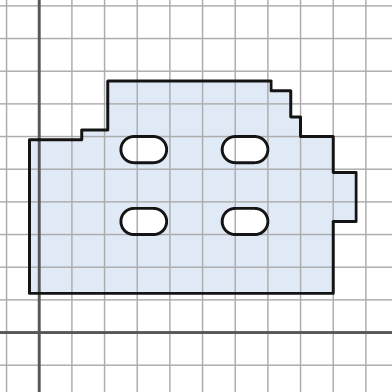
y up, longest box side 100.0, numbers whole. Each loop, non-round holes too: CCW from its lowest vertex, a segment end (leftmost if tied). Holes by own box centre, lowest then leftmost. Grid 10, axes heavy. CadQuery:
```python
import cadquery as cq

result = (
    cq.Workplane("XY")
    .moveTo(-3.0, 12.0)
    .lineTo(90.0, 12.0)
    .lineTo(90.0, 34.0)
    .lineTo(97.0, 34.0)
    .lineTo(97.0, 49.0)
    .lineTo(90.0, 49.0)
    .lineTo(90.0, 60.0)
    .lineTo(80.0, 60.0)
    .lineTo(80.0, 66.0)
    .lineTo(77.0, 66.0)
    .lineTo(77.0, 74.0)
    .lineTo(71.0, 74.0)
    .lineTo(71.0, 77.0)
    .lineTo(21.0, 77.0)
    .lineTo(21.0, 62.0)
    .lineTo(13.0, 62.0)
    .lineTo(13.0, 59.0)
    .lineTo(-3.0, 59.0)
    .close()
    .moveTo(29.0, 30.0)
    .lineTo(35.0, 30.0)
    .threePointArc((39.0, 34.0), (35.0, 38.0))
    .lineTo(29.0, 38.0)
    .threePointArc((25.0, 34.0), (29.0, 30.0))
    .close()
    .moveTo(60.0, 30.0)
    .lineTo(66.0, 30.0)
    .threePointArc((70.0, 34.0), (66.0, 38.0))
    .lineTo(60.0, 38.0)
    .threePointArc((56.0, 34.0), (60.0, 30.0))
    .close()
    .moveTo(29.0, 52.0)
    .lineTo(35.0, 52.0)
    .threePointArc((39.0, 56.0), (35.0, 60.0))
    .lineTo(29.0, 60.0)
    .threePointArc((25.0, 56.0), (29.0, 52.0))
    .close()
    .moveTo(60.0, 52.0)
    .lineTo(66.0, 52.0)
    .threePointArc((70.0, 56.0), (66.0, 60.0))
    .lineTo(60.0, 60.0)
    .threePointArc((56.0, 56.0), (60.0, 52.0))
    .close()
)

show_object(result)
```